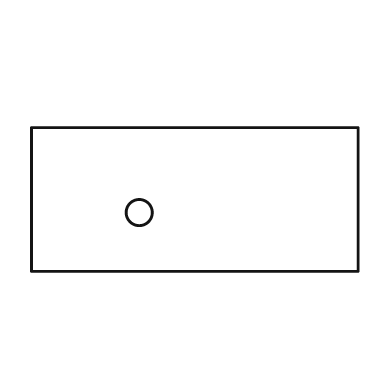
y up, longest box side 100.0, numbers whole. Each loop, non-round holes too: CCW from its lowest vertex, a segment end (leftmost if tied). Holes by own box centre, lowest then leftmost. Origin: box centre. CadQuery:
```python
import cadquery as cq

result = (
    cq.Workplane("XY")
    .moveTo(-50.0, -22.0)
    .lineTo(50.0, -22.0)
    .lineTo(50.0, 22.0)
    .lineTo(-50.0, 22.0)
    .close()
    .moveTo(-17.0, -4.0)
    .circle(4.0)
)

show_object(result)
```